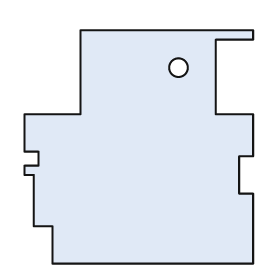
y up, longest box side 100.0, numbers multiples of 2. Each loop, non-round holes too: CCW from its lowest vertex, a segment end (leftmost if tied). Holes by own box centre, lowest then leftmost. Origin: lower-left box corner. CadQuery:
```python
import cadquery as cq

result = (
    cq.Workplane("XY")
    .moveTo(12.0, 0.0)
    .lineTo(98.0, 0.0)
    .lineTo(98.0, 30.0)
    .lineTo(92.0, 30.0)
    .lineTo(92.0, 46.0)
    .lineTo(98.0, 46.0)
    .lineTo(98.0, 64.0)
    .lineTo(82.0, 64.0)
    .lineTo(82.0, 96.0)
    .lineTo(98.0, 96.0)
    .lineTo(98.0, 100.0)
    .lineTo(24.0, 100.0)
    .lineTo(24.0, 64.0)
    .lineTo(0.0, 64.0)
    .lineTo(0.0, 48.0)
    .lineTo(6.0, 48.0)
    .lineTo(6.0, 42.0)
    .lineTo(0.0, 42.0)
    .lineTo(0.0, 38.0)
    .lineTo(4.0, 38.0)
    .lineTo(4.0, 16.0)
    .lineTo(12.0, 16.0)
    .close()
    .moveTo(66.0, 84.0)
    .circle(4.0)
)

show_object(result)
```